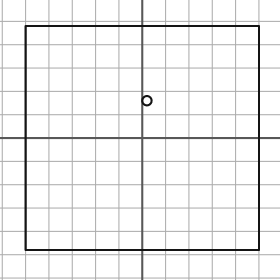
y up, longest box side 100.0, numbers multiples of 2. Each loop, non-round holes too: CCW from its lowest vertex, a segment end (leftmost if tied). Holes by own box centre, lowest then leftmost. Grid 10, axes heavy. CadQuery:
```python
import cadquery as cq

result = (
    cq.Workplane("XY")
    .moveTo(-50.0, -48.0)
    .lineTo(50.0, -48.0)
    .lineTo(50.0, 48.0)
    .lineTo(-50.0, 48.0)
    .close()
    .moveTo(2.0, 16.0)
    .circle(2.0)
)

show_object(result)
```